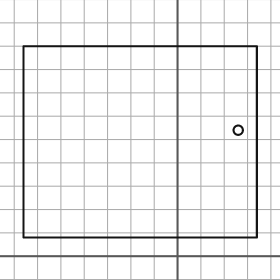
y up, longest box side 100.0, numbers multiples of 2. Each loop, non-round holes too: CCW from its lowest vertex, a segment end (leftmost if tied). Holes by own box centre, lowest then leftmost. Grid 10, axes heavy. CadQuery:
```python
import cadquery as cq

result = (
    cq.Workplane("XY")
    .moveTo(-66.0, 8.0)
    .lineTo(34.0, 8.0)
    .lineTo(34.0, 90.0)
    .lineTo(-66.0, 90.0)
    .close()
    .moveTo(26.0, 54.0)
    .circle(2.0)
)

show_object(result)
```